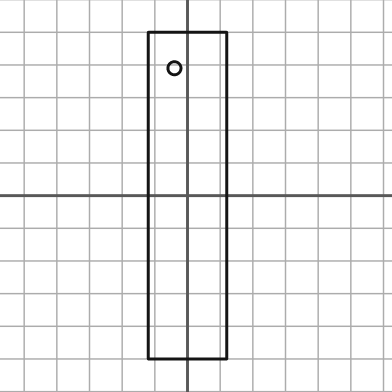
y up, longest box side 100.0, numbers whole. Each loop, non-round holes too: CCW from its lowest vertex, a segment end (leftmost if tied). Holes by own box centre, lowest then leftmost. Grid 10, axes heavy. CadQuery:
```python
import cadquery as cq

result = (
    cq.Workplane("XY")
    .moveTo(-12.0, -50.0)
    .lineTo(12.0, -50.0)
    .lineTo(12.0, 50.0)
    .lineTo(-12.0, 50.0)
    .close()
    .moveTo(-4.0, 39.0)
    .circle(2.0)
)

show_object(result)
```